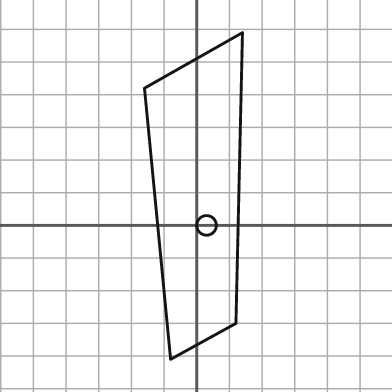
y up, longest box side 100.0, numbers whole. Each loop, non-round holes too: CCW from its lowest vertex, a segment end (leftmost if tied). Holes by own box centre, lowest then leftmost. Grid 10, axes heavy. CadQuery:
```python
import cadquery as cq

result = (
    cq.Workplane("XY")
    .moveTo(-8.0, -41.0)
    .lineTo(12.0, -30.0)
    .lineTo(14.0, 59.0)
    .lineTo(-16.0, 42.0)
    .close()
    .moveTo(3.0, 0.0)
    .circle(3.0)
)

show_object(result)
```